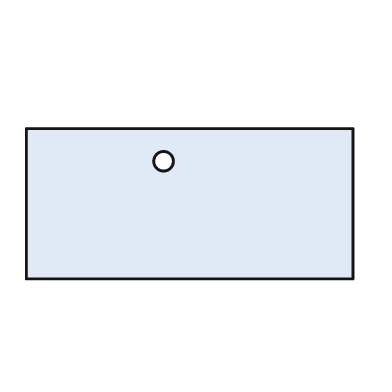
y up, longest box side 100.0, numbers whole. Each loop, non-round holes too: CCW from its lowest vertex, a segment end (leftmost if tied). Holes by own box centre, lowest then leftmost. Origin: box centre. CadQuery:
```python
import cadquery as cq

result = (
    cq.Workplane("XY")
    .moveTo(-50.0, -23.0)
    .lineTo(50.0, -23.0)
    .lineTo(50.0, 23.0)
    .lineTo(-50.0, 23.0)
    .close()
    .moveTo(-8.0, 13.0)
    .circle(3.0)
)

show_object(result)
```